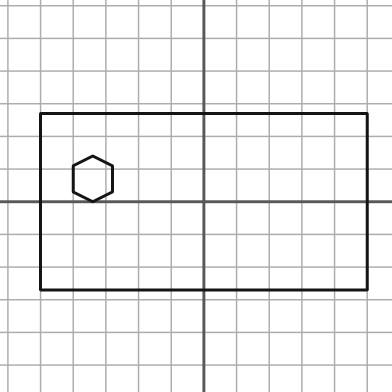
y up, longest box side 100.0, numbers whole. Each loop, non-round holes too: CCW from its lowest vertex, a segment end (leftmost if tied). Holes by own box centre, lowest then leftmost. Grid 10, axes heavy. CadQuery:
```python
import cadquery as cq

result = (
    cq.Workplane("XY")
    .moveTo(-50.0, -27.0)
    .lineTo(50.0, -27.0)
    .lineTo(50.0, 27.0)
    .lineTo(-50.0, 27.0)
    .close()
    .moveTo(-34.0, 0.0)
    .lineTo(-28.0, 3.0)
    .lineTo(-28.0, 11.0)
    .lineTo(-34.0, 14.0)
    .lineTo(-40.0, 11.0)
    .lineTo(-40.0, 3.0)
    .close()
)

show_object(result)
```